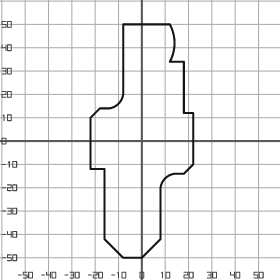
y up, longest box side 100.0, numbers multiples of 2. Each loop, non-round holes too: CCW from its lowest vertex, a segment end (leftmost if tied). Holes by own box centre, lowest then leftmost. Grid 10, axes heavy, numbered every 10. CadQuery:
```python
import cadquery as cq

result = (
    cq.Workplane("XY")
    .moveTo(-8.0, -50.0)
    .lineTo(0.0, -50.0)
    .lineTo(8.0, -42.0)
    .lineTo(8.0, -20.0)
    .threePointArc((10.0, -16.0), (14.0, -14.0))
    .lineTo(18.0, -14.0)
    .lineTo(22.0, -10.0)
    .lineTo(22.0, 12.0)
    .lineTo(18.0, 12.0)
    .lineTo(18.0, 34.0)
    .lineTo(12.0, 34.0)
    .threePointArc((14.0, 42.0), (12.0, 50.0))
    .lineTo(-8.0, 50.0)
    .lineTo(-8.0, 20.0)
    .threePointArc((-10.0, 16.0), (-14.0, 14.0))
    .lineTo(-18.0, 14.0)
    .lineTo(-22.0, 10.0)
    .lineTo(-22.0, -12.0)
    .lineTo(-16.0, -12.0)
    .lineTo(-16.0, -42.0)
    .close()
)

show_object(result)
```